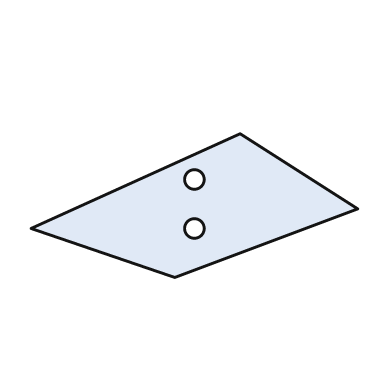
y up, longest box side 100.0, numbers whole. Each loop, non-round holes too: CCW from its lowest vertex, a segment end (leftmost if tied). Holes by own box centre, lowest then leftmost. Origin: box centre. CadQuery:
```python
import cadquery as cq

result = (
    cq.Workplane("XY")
    .moveTo(-6.0, -22.0)
    .lineTo(50.0, -1.0)
    .lineTo(14.0, 22.0)
    .lineTo(-50.0, -7.0)
    .close()
    .moveTo(0.0, -7.0)
    .circle(3.0)
    .moveTo(0.0, 8.0)
    .circle(3.0)
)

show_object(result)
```